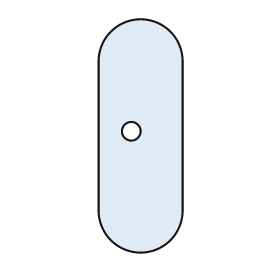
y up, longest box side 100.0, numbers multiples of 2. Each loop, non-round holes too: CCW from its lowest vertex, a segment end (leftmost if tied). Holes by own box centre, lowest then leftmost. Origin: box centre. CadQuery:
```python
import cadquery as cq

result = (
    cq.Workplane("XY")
    .moveTo(-18.0, -32.0)
    .threePointArc((0.0, -50.0), (18.0, -32.0))
    .lineTo(18.0, 32.0)
    .threePointArc((0.0, 50.0), (-18.0, 32.0))
    .close()
    .moveTo(-4.0, 2.0)
    .circle(4.0)
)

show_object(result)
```